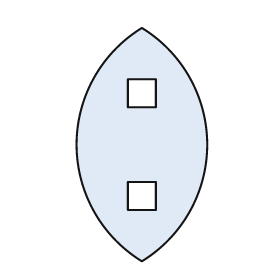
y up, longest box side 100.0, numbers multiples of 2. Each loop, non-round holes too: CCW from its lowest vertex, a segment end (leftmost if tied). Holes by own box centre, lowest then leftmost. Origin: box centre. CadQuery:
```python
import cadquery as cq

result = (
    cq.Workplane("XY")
    .moveTo(0.0, -50.0)
    .threePointArc((28.0, 0.0), (0.0, 50.0))
    .threePointArc((-28.0, 0.0), (0.0, -50.0))
    .close()
    .moveTo(-6.0, -28.0)
    .lineTo(6.0, -28.0)
    .lineTo(6.0, -16.0)
    .lineTo(-6.0, -16.0)
    .close()
    .moveTo(-6.0, 16.0)
    .lineTo(6.0, 16.0)
    .lineTo(6.0, 28.0)
    .lineTo(-6.0, 28.0)
    .close()
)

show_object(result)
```